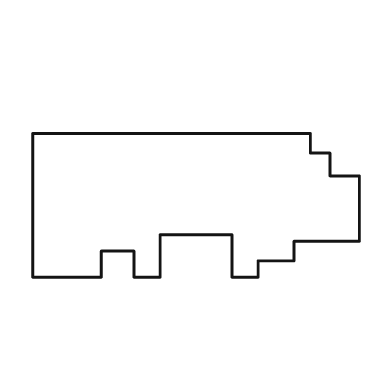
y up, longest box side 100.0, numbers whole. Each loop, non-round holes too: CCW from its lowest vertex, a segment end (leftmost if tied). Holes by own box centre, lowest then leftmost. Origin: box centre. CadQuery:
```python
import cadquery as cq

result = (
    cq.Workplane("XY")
    .moveTo(-50.0, -22.0)
    .lineTo(-29.0, -22.0)
    .lineTo(-29.0, -14.0)
    .lineTo(-19.0, -14.0)
    .lineTo(-19.0, -22.0)
    .lineTo(-11.0, -22.0)
    .lineTo(-11.0, -9.0)
    .lineTo(11.0, -9.0)
    .lineTo(11.0, -22.0)
    .lineTo(19.0, -22.0)
    .lineTo(19.0, -17.0)
    .lineTo(30.0, -17.0)
    .lineTo(30.0, -11.0)
    .lineTo(50.0, -11.0)
    .lineTo(50.0, 9.0)
    .lineTo(41.0, 9.0)
    .lineTo(41.0, 16.0)
    .lineTo(35.0, 16.0)
    .lineTo(35.0, 22.0)
    .lineTo(-50.0, 22.0)
    .close()
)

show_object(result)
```